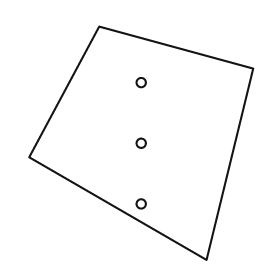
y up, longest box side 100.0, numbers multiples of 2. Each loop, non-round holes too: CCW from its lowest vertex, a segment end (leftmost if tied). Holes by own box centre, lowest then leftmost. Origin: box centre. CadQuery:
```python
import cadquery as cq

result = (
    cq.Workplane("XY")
    .moveTo(28.0, -50.0)
    .lineTo(48.0, 32.0)
    .lineTo(-18.0, 50.0)
    .lineTo(-48.0, -6.0)
    .close()
    .moveTo(0.0, -26.0)
    .circle(2.0)
    .moveTo(0.0, 0.0)
    .circle(2.0)
    .moveTo(0.0, 26.0)
    .circle(2.0)
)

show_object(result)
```